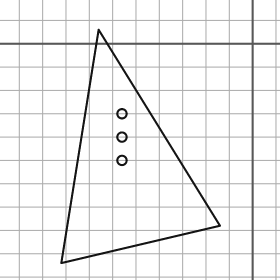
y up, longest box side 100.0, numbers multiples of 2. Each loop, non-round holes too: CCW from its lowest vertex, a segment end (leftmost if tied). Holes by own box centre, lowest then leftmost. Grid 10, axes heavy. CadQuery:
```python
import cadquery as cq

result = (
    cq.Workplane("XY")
    .moveTo(-82.0, -94.0)
    .lineTo(-14.0, -78.0)
    .lineTo(-66.0, 6.0)
    .close()
    .moveTo(-56.0, -50.0)
    .circle(2.0)
    .moveTo(-56.0, -40.0)
    .circle(2.0)
    .moveTo(-56.0, -30.0)
    .circle(2.0)
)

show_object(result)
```